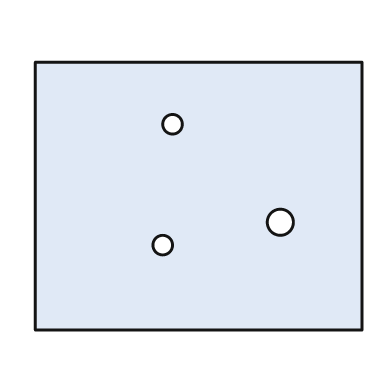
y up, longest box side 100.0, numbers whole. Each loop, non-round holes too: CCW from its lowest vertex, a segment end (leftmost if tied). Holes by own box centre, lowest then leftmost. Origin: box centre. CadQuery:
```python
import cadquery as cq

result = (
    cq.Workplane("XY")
    .moveTo(-50.0, -41.0)
    .lineTo(50.0, -41.0)
    .lineTo(50.0, 41.0)
    .lineTo(-50.0, 41.0)
    .close()
    .moveTo(-11.0, -15.0)
    .circle(3.0)
    .moveTo(25.0, -8.0)
    .circle(4.0)
    .moveTo(-8.0, 22.0)
    .circle(3.0)
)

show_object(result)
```